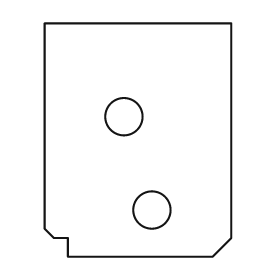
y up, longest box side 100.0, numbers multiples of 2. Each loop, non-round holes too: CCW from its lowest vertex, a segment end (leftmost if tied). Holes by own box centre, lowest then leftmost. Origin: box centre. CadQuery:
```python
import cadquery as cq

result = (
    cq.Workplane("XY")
    .moveTo(-30.0, -50.0)
    .lineTo(32.0, -50.0)
    .lineTo(40.0, -42.0)
    .lineTo(40.0, 50.0)
    .lineTo(-40.0, 50.0)
    .lineTo(-40.0, -38.0)
    .lineTo(-36.0, -42.0)
    .lineTo(-30.0, -42.0)
    .close()
    .moveTo(6.0, -30.0)
    .circle(8.0)
    .moveTo(-6.0, 10.0)
    .circle(8.0)
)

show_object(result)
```